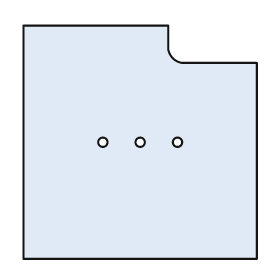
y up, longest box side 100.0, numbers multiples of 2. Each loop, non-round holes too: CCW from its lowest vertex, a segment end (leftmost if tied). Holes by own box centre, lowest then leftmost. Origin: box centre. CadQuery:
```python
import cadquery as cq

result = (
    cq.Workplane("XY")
    .moveTo(-50.0, -50.0)
    .lineTo(50.0, -50.0)
    .lineTo(50.0, 34.0)
    .lineTo(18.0, 34.0)
    .threePointArc((14.0, 36.0), (12.0, 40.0))
    .lineTo(12.0, 50.0)
    .lineTo(-50.0, 50.0)
    .close()
    .moveTo(-16.0, 0.0)
    .circle(2.0)
    .moveTo(0.0, 0.0)
    .circle(2.0)
    .moveTo(16.0, 0.0)
    .circle(2.0)
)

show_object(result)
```